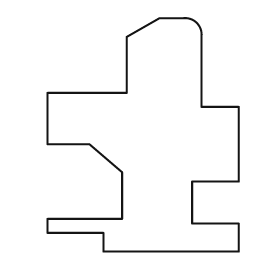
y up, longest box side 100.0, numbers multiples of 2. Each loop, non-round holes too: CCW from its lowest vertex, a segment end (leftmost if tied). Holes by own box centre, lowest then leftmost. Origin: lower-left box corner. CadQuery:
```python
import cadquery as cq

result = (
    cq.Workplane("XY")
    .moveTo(24.0, 0.0)
    .lineTo(82.0, 0.0)
    .lineTo(82.0, 12.0)
    .lineTo(62.0, 12.0)
    .lineTo(62.0, 30.0)
    .lineTo(82.0, 30.0)
    .lineTo(82.0, 62.0)
    .lineTo(66.0, 62.0)
    .lineTo(66.0, 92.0)
    .threePointArc((64.0, 98.0), (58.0, 100.0))
    .lineTo(48.0, 100.0)
    .lineTo(34.0, 92.0)
    .lineTo(34.0, 68.0)
    .lineTo(0.0, 68.0)
    .lineTo(0.0, 46.0)
    .lineTo(18.0, 46.0)
    .lineTo(32.0, 34.0)
    .lineTo(32.0, 14.0)
    .lineTo(0.0, 14.0)
    .lineTo(0.0, 8.0)
    .lineTo(24.0, 8.0)
    .close()
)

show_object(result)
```